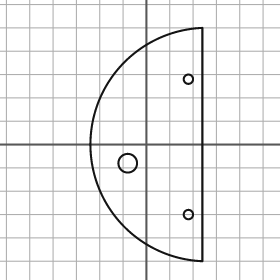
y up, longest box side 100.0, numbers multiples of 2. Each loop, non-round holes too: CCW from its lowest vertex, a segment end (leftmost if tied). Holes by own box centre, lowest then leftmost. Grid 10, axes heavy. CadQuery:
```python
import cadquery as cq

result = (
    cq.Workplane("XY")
    .moveTo(24.0, -50.0)
    .lineTo(24.0, 50.0)
    .threePointArc((-24.0, 0.0), (24.0, -50.0))
    .close()
    .moveTo(18.0, -30.0)
    .circle(2.0)
    .moveTo(-8.0, -8.0)
    .circle(4.0)
    .moveTo(18.0, 28.0)
    .circle(2.0)
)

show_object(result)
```